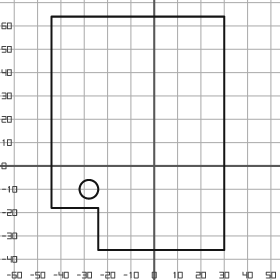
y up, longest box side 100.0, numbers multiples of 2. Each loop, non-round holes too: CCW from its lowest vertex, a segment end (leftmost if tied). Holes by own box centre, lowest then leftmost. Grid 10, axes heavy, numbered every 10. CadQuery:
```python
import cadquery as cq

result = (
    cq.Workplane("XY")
    .moveTo(-24.0, -36.0)
    .lineTo(30.0, -36.0)
    .lineTo(30.0, 64.0)
    .lineTo(-44.0, 64.0)
    .lineTo(-44.0, -18.0)
    .lineTo(-24.0, -18.0)
    .close()
    .moveTo(-28.0, -10.0)
    .circle(4.0)
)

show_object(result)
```